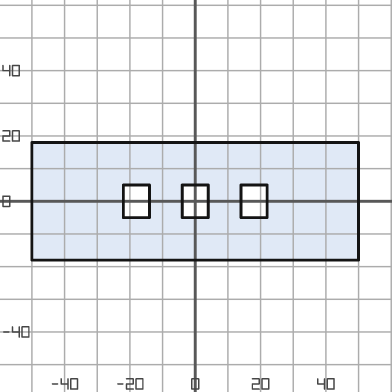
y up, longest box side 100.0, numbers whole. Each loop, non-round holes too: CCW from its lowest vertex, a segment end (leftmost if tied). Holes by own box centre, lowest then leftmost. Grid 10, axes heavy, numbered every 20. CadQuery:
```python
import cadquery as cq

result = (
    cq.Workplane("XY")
    .moveTo(-50.0, -18.0)
    .lineTo(50.0, -18.0)
    .lineTo(50.0, 18.0)
    .lineTo(-50.0, 18.0)
    .close()
    .moveTo(-22.0, -5.0)
    .lineTo(-14.0, -5.0)
    .lineTo(-14.0, 5.0)
    .lineTo(-22.0, 5.0)
    .close()
    .moveTo(-4.0, -5.0)
    .lineTo(4.0, -5.0)
    .lineTo(4.0, 5.0)
    .lineTo(-4.0, 5.0)
    .close()
    .moveTo(14.0, -5.0)
    .lineTo(22.0, -5.0)
    .lineTo(22.0, 5.0)
    .lineTo(14.0, 5.0)
    .close()
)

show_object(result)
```